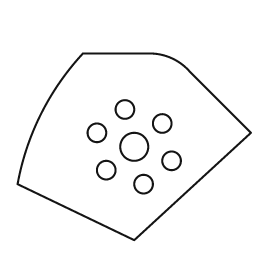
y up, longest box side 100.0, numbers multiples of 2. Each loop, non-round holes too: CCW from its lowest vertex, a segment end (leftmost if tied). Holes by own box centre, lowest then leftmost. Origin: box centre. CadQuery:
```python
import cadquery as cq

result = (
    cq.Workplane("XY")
    .moveTo(0.0, -40.0)
    .lineTo(50.0, 6.0)
    .lineTo(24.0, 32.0)
    .threePointArc((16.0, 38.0), (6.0, 40.0))
    .lineTo(-22.0, 40.0)
    .threePointArc((-40.0, 14.0), (-50.0, -16.0))
    .close()
    .moveTo(4.0, -16.0)
    .circle(4.0)
    .moveTo(-12.0, -10.0)
    .circle(4.0)
    .moveTo(16.0, -6.0)
    .circle(4.0)
    .moveTo(0.0, 0.0)
    .circle(6.0)
    .moveTo(-16.0, 6.0)
    .circle(4.0)
    .moveTo(12.0, 10.0)
    .circle(4.0)
    .moveTo(-4.0, 16.0)
    .circle(4.0)
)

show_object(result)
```